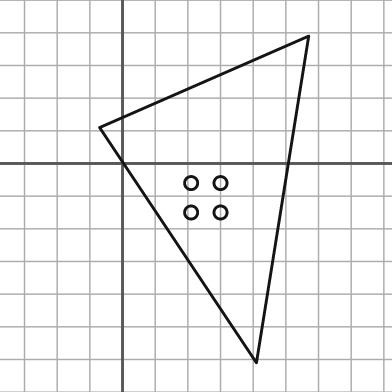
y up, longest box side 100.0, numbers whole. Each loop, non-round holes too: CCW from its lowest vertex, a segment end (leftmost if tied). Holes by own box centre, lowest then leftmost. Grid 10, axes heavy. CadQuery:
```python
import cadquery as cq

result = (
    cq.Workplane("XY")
    .moveTo(41.0, -61.0)
    .lineTo(57.0, 39.0)
    .lineTo(-7.0, 11.0)
    .close()
    .moveTo(21.0, -15.0)
    .circle(2.0)
    .moveTo(30.0, -15.0)
    .circle(2.0)
    .moveTo(21.0, -6.0)
    .circle(2.0)
    .moveTo(30.0, -6.0)
    .circle(2.0)
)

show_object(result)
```